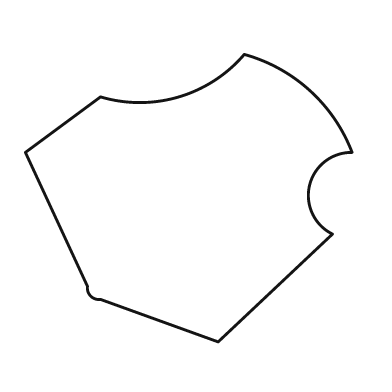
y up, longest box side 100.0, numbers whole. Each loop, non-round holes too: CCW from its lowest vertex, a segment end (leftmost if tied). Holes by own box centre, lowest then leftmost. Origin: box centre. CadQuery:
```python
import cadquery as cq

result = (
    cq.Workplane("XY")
    .moveTo(9.0, -44.0)
    .lineTo(44.0, -11.0)
    .threePointArc((37.0, 4.0), (50.0, 14.0))
    .threePointArc((37.0, 33.0), (17.0, 44.0))
    .threePointArc((-3.0, 31.0), (-27.0, 31.0))
    .lineTo(-50.0, 14.0)
    .lineTo(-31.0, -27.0)
    .threePointArc((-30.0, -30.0), (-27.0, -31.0))
    .close()
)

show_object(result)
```